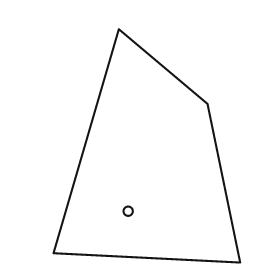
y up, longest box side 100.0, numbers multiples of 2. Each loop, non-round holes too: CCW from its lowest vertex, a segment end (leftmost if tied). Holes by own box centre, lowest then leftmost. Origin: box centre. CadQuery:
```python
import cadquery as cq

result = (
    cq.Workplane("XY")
    .moveTo(40.0, -50.0)
    .lineTo(26.0, 18.0)
    .lineTo(-12.0, 50.0)
    .lineTo(-40.0, -46.0)
    .close()
    .moveTo(-8.0, -28.0)
    .circle(2.0)
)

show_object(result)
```